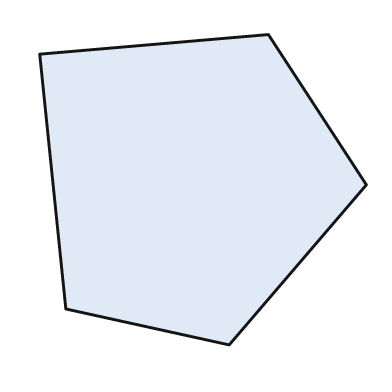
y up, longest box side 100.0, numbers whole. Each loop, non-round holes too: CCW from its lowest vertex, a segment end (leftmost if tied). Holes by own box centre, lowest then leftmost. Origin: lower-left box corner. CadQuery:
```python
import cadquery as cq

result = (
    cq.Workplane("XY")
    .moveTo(58.0, 0.0)
    .lineTo(100.0, 49.0)
    .lineTo(70.0, 95.0)
    .lineTo(0.0, 89.0)
    .lineTo(8.0, 11.0)
    .close()
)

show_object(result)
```